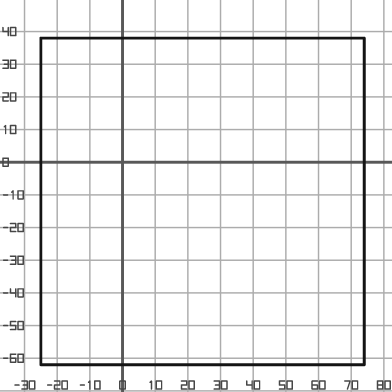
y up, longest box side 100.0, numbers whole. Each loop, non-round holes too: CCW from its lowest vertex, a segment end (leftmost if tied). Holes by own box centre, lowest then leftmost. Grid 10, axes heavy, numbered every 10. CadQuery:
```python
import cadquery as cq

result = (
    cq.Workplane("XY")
    .moveTo(-25.0, -62.0)
    .lineTo(74.0, -62.0)
    .lineTo(74.0, 38.0)
    .lineTo(-25.0, 38.0)
    .close()
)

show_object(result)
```